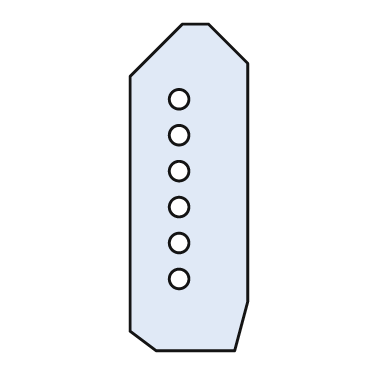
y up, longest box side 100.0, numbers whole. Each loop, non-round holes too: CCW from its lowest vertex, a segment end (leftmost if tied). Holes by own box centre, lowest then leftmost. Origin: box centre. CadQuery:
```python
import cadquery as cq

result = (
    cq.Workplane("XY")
    .moveTo(-10.0, -50.0)
    .lineTo(14.0, -50.0)
    .lineTo(18.0, -35.0)
    .lineTo(18.0, 38.0)
    .lineTo(6.0, 50.0)
    .lineTo(-2.0, 50.0)
    .lineTo(-18.0, 34.0)
    .lineTo(-18.0, -44.0)
    .close()
    .moveTo(-3.0, -28.0)
    .circle(3.0)
    .moveTo(-3.0, -17.0)
    .circle(3.0)
    .moveTo(-3.0, -6.0)
    .circle(3.0)
    .moveTo(-3.0, 5.0)
    .circle(3.0)
    .moveTo(-3.0, 16.0)
    .circle(3.0)
    .moveTo(-3.0, 27.0)
    .circle(3.0)
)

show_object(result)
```